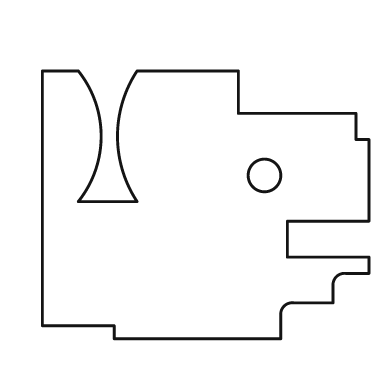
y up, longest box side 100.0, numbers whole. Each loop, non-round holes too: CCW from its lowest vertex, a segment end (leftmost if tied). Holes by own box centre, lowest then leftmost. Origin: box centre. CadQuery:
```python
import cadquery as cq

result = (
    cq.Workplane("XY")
    .moveTo(-28.0, -41.0)
    .lineTo(23.0, -41.0)
    .lineTo(23.0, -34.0)
    .threePointArc((24.0, -31.0), (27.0, -30.0))
    .lineTo(39.0, -30.0)
    .lineTo(39.0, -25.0)
    .threePointArc((40.0, -22.0), (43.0, -21.0))
    .lineTo(50.0, -21.0)
    .lineTo(50.0, -16.0)
    .lineTo(25.0, -16.0)
    .lineTo(25.0, -5.0)
    .lineTo(50.0, -5.0)
    .lineTo(50.0, 20.0)
    .lineTo(46.0, 20.0)
    .lineTo(46.0, 28.0)
    .lineTo(10.0, 28.0)
    .lineTo(10.0, 41.0)
    .lineTo(-21.0, 41.0)
    .threePointArc((-27.0, 21.0), (-21.0, 1.0))
    .lineTo(-39.0, 1.0)
    .threePointArc((-32.0, 21.0), (-39.0, 41.0))
    .lineTo(-50.0, 41.0)
    .lineTo(-50.0, -37.0)
    .lineTo(-28.0, -37.0)
    .close()
    .moveTo(18.0, 9.0)
    .circle(5.0)
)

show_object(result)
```